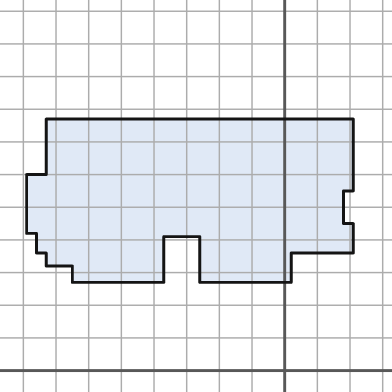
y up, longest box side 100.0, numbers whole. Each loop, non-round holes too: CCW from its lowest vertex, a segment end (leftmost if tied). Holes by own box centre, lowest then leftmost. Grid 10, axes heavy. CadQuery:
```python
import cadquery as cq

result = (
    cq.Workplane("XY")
    .moveTo(-65.0, 27.0)
    .lineTo(-37.0, 27.0)
    .lineTo(-37.0, 41.0)
    .lineTo(-26.0, 41.0)
    .lineTo(-26.0, 27.0)
    .lineTo(2.0, 27.0)
    .lineTo(2.0, 36.0)
    .lineTo(21.0, 36.0)
    .lineTo(21.0, 45.0)
    .lineTo(18.0, 45.0)
    .lineTo(18.0, 55.0)
    .lineTo(21.0, 55.0)
    .lineTo(21.0, 77.0)
    .lineTo(-73.0, 77.0)
    .lineTo(-73.0, 60.0)
    .lineTo(-79.0, 60.0)
    .lineTo(-79.0, 42.0)
    .lineTo(-76.0, 42.0)
    .lineTo(-76.0, 36.0)
    .lineTo(-73.0, 36.0)
    .lineTo(-73.0, 32.0)
    .lineTo(-65.0, 32.0)
    .close()
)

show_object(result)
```